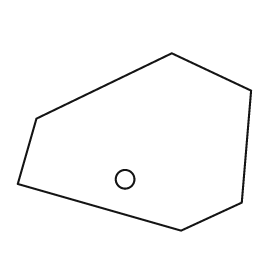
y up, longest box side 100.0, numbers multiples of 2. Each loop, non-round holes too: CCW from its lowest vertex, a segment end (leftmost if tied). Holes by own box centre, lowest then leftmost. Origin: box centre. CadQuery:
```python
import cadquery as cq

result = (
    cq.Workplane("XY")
    .moveTo(20.0, -38.0)
    .lineTo(46.0, -26.0)
    .lineTo(50.0, 22.0)
    .lineTo(16.0, 38.0)
    .lineTo(-42.0, 10.0)
    .lineTo(-50.0, -18.0)
    .close()
    .moveTo(-4.0, -16.0)
    .circle(4.0)
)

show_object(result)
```